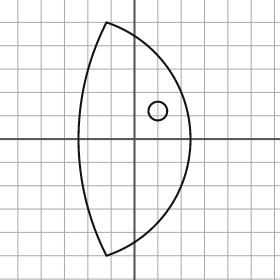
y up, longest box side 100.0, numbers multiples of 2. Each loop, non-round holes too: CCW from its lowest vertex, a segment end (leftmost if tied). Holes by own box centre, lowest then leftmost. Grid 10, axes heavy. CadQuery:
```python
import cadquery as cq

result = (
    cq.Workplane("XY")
    .moveTo(-12.0, -50.0)
    .threePointArc((24.0, 0.0), (-12.0, 50.0))
    .threePointArc((-24.0, 0.0), (-12.0, -50.0))
    .close()
    .moveTo(10.0, 12.0)
    .circle(4.0)
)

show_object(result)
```